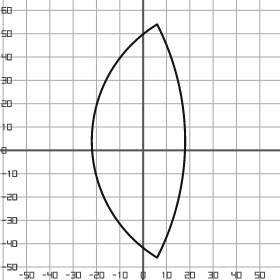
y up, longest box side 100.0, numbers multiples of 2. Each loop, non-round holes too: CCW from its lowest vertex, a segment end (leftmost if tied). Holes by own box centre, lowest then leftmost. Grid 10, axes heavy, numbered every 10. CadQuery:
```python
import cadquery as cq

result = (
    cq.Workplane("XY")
    .moveTo(6.0, -46.0)
    .threePointArc((18.0, 4.0), (6.0, 54.0))
    .threePointArc((-22.0, 4.0), (6.0, -46.0))
    .close()
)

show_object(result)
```